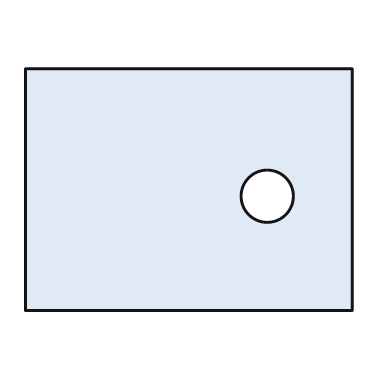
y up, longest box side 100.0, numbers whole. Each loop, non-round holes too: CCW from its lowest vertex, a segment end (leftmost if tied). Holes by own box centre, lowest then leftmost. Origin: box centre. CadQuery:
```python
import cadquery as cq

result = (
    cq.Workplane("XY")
    .moveTo(-50.0, -37.0)
    .lineTo(50.0, -37.0)
    .lineTo(50.0, 37.0)
    .lineTo(-50.0, 37.0)
    .close()
    .moveTo(24.0, -2.0)
    .circle(8.0)
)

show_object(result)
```